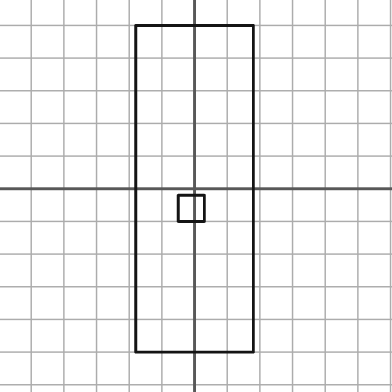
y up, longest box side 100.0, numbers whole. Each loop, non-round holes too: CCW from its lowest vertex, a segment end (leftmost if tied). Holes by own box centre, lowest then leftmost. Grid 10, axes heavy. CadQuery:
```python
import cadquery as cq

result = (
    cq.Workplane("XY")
    .moveTo(-18.0, -50.0)
    .lineTo(18.0, -50.0)
    .lineTo(18.0, 50.0)
    .lineTo(-18.0, 50.0)
    .close()
    .moveTo(-5.0, -10.0)
    .lineTo(3.0, -10.0)
    .lineTo(3.0, -2.0)
    .lineTo(-5.0, -2.0)
    .close()
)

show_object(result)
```